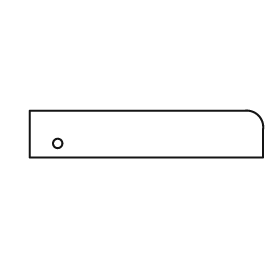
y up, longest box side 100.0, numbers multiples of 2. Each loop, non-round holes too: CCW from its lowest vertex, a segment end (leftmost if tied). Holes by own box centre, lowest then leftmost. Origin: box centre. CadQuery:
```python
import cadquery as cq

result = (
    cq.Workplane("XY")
    .moveTo(-50.0, -10.0)
    .lineTo(50.0, -10.0)
    .lineTo(50.0, 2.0)
    .threePointArc((48.0, 8.0), (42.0, 10.0))
    .lineTo(-50.0, 10.0)
    .close()
    .moveTo(-38.0, -4.0)
    .circle(2.0)
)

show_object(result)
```